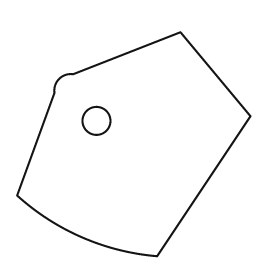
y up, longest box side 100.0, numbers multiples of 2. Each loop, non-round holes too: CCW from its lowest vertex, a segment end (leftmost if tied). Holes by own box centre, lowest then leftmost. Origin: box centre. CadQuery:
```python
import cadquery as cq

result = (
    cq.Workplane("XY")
    .moveTo(10.0, -48.0)
    .lineTo(50.0, 12.0)
    .lineTo(20.0, 48.0)
    .lineTo(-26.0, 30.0)
    .threePointArc((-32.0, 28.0), (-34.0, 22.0))
    .lineTo(-50.0, -22.0)
    .threePointArc((-22.0, -40.0), (10.0, -48.0))
    .close()
    .moveTo(-16.0, 10.0)
    .circle(6.0)
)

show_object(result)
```